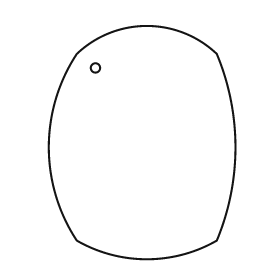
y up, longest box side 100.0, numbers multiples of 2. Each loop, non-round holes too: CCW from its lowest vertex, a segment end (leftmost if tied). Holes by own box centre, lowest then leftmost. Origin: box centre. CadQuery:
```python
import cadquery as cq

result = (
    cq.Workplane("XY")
    .moveTo(-28.0, -42.0)
    .threePointArc((2.0, -50.0), (32.0, -42.0))
    .threePointArc((40.0, -2.0), (32.0, 38.0))
    .threePointArc((2.0, 50.0), (-28.0, 38.0))
    .threePointArc((-40.0, -2.0), (-28.0, -42.0))
    .close()
    .moveTo(-20.0, 32.0)
    .circle(2.0)
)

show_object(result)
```